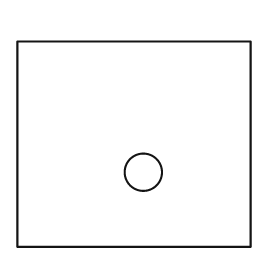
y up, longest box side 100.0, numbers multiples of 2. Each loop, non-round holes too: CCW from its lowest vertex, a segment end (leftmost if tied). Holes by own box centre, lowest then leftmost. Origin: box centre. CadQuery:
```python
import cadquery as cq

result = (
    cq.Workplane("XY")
    .moveTo(-50.0, -44.0)
    .lineTo(50.0, -44.0)
    .lineTo(50.0, 44.0)
    .lineTo(-50.0, 44.0)
    .close()
    .moveTo(4.0, -12.0)
    .circle(8.0)
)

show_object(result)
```